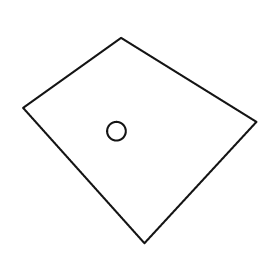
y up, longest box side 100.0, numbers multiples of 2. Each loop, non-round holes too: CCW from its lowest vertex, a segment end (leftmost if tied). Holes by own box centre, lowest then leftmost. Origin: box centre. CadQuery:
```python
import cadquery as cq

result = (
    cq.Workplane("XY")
    .moveTo(2.0, -44.0)
    .lineTo(50.0, 8.0)
    .lineTo(-8.0, 44.0)
    .lineTo(-50.0, 14.0)
    .close()
    .moveTo(-10.0, 4.0)
    .circle(4.0)
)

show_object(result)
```